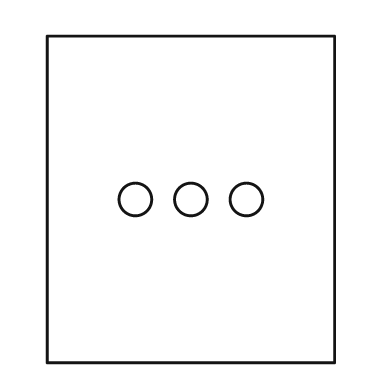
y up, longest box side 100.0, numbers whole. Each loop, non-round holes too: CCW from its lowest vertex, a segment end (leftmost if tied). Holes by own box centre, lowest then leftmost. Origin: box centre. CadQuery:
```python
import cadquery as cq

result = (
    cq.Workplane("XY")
    .moveTo(-44.0, -50.0)
    .lineTo(44.0, -50.0)
    .lineTo(44.0, 50.0)
    .lineTo(-44.0, 50.0)
    .close()
    .moveTo(-17.0, 0.0)
    .circle(5.0)
    .moveTo(0.0, 0.0)
    .circle(5.0)
    .moveTo(17.0, 0.0)
    .circle(5.0)
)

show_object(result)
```